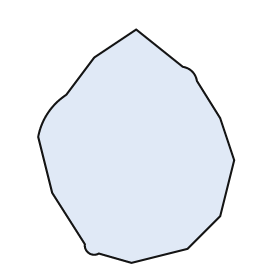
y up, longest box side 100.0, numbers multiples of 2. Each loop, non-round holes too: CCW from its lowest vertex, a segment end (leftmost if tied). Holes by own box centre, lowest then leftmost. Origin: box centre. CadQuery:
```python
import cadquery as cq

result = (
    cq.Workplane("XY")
    .moveTo(-2.0, -50.0)
    .lineTo(22.0, -44.0)
    .lineTo(36.0, -30.0)
    .lineTo(42.0, -6.0)
    .lineTo(36.0, 12.0)
    .lineTo(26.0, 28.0)
    .threePointArc((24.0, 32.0), (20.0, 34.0))
    .lineTo(0.0, 50.0)
    .lineTo(-18.0, 38.0)
    .lineTo(-30.0, 22.0)
    .threePointArc((-38.0, 14.0), (-42.0, 4.0))
    .lineTo(-36.0, -20.0)
    .lineTo(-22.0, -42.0)
    .threePointArc((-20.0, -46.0), (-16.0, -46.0))
    .close()
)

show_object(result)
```